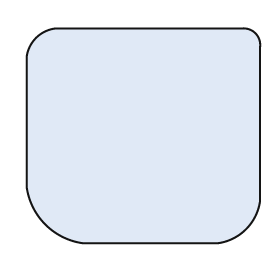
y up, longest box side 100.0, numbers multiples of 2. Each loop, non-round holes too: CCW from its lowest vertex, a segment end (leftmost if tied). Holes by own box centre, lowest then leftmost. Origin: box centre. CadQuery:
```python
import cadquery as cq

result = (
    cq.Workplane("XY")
    .moveTo(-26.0, -46.0)
    .lineTo(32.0, -46.0)
    .threePointArc((44.0, -40.0), (50.0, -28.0))
    .lineTo(50.0, 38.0)
    .threePointArc((48.0, 44.0), (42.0, 46.0))
    .lineTo(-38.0, 46.0)
    .threePointArc((-46.0, 42.0), (-50.0, 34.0))
    .lineTo(-50.0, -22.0)
    .threePointArc((-42.0, -38.0), (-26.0, -46.0))
    .close()
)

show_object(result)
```